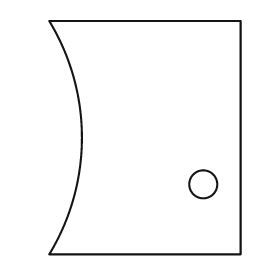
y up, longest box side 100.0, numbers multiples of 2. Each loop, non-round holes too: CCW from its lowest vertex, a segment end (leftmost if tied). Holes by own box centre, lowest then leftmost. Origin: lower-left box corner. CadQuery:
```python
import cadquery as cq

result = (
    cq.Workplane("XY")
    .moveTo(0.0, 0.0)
    .lineTo(82.0, 0.0)
    .lineTo(82.0, 100.0)
    .lineTo(0.0, 100.0)
    .threePointArc((14.0, 50.0), (0.0, 0.0))
    .close()
    .moveTo(66.0, 30.0)
    .circle(6.0)
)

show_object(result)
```